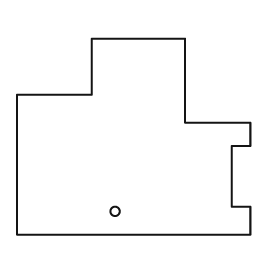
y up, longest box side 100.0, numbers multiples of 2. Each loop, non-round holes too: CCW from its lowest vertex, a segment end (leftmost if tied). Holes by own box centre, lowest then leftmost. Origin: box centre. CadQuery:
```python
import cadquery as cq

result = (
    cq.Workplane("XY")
    .moveTo(-50.0, -42.0)
    .lineTo(50.0, -42.0)
    .lineTo(50.0, -30.0)
    .lineTo(42.0, -30.0)
    .lineTo(42.0, -4.0)
    .lineTo(50.0, -4.0)
    .lineTo(50.0, 6.0)
    .lineTo(22.0, 6.0)
    .lineTo(22.0, 42.0)
    .lineTo(-18.0, 42.0)
    .lineTo(-18.0, 18.0)
    .lineTo(-50.0, 18.0)
    .close()
    .moveTo(-8.0, -32.0)
    .circle(2.0)
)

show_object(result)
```